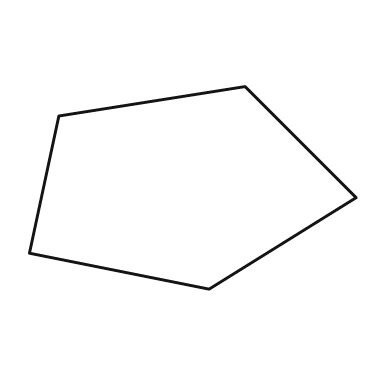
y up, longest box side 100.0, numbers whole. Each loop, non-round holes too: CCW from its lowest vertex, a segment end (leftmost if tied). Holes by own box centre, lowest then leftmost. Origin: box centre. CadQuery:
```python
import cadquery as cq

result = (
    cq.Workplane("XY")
    .moveTo(5.0, -31.0)
    .lineTo(50.0, -3.0)
    .lineTo(16.0, 31.0)
    .lineTo(-41.0, 22.0)
    .lineTo(-50.0, -20.0)
    .close()
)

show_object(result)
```